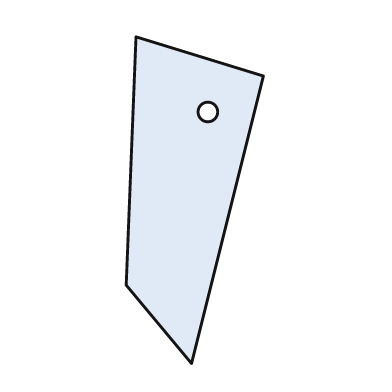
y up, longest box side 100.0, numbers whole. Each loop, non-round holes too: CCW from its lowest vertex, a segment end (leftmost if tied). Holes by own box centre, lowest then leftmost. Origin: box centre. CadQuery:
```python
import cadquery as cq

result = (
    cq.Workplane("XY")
    .moveTo(-1.0, -50.0)
    .lineTo(21.0, 38.0)
    .lineTo(-18.0, 50.0)
    .lineTo(-21.0, -26.0)
    .close()
    .moveTo(4.0, 27.0)
    .circle(3.0)
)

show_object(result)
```